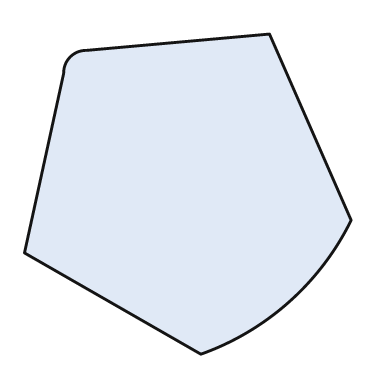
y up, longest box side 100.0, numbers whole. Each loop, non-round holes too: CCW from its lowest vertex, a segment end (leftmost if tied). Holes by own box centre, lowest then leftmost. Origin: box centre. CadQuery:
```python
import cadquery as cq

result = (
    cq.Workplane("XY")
    .moveTo(4.0, -49.0)
    .threePointArc((31.0, -33.0), (50.0, -8.0))
    .lineTo(25.0, 49.0)
    .lineTo(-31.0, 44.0)
    .threePointArc((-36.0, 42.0), (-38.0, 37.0))
    .lineTo(-50.0, -18.0)
    .close()
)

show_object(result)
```